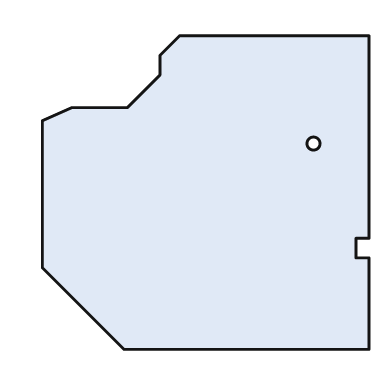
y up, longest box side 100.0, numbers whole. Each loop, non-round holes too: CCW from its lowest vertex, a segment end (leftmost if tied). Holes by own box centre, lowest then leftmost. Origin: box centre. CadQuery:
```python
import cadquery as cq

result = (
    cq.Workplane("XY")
    .moveTo(-25.0, -48.0)
    .lineTo(50.0, -48.0)
    .lineTo(50.0, -20.0)
    .lineTo(46.0, -20.0)
    .lineTo(46.0, -14.0)
    .lineTo(50.0, -14.0)
    .lineTo(50.0, 48.0)
    .lineTo(-8.0, 48.0)
    .lineTo(-14.0, 42.0)
    .lineTo(-14.0, 36.0)
    .lineTo(-24.0, 26.0)
    .lineTo(-41.0, 26.0)
    .lineTo(-50.0, 22.0)
    .lineTo(-50.0, -23.0)
    .close()
    .moveTo(33.0, 15.0)
    .circle(2.0)
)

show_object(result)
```